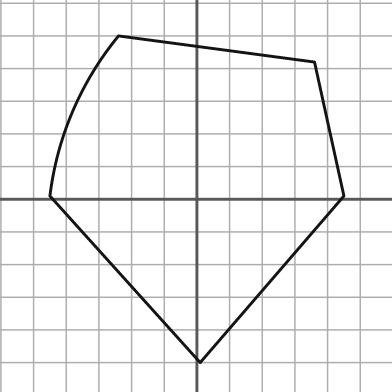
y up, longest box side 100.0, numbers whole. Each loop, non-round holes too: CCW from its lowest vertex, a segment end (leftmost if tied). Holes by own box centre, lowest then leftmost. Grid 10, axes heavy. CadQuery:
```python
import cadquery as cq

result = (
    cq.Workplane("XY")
    .moveTo(1.0, -50.0)
    .lineTo(45.0, 1.0)
    .lineTo(36.0, 42.0)
    .lineTo(-24.0, 50.0)
    .threePointArc((-38.0, 27.0), (-45.0, 1.0))
    .close()
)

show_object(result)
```